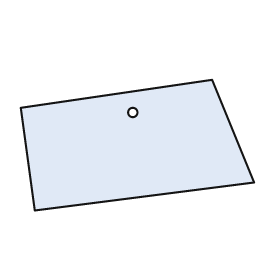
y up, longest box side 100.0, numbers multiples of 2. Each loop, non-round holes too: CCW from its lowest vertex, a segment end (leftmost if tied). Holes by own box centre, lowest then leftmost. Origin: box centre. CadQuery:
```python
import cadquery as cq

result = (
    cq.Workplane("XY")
    .moveTo(-44.0, -28.0)
    .lineTo(50.0, -16.0)
    .lineTo(32.0, 28.0)
    .lineTo(-50.0, 16.0)
    .close()
    .moveTo(-2.0, 14.0)
    .circle(2.0)
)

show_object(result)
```